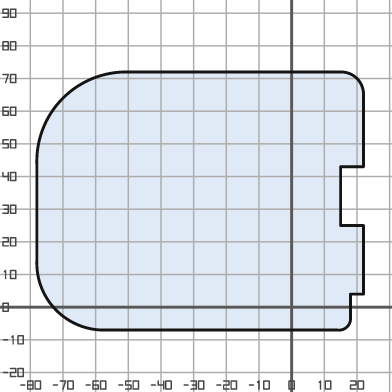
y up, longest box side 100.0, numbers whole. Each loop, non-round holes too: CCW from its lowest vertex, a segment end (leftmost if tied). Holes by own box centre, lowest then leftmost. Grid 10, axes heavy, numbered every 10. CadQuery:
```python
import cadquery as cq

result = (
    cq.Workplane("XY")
    .moveTo(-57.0, -7.0)
    .lineTo(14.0, -7.0)
    .threePointArc((17.0, -6.0), (18.0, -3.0))
    .lineTo(18.0, 4.0)
    .lineTo(22.0, 4.0)
    .lineTo(22.0, 25.0)
    .lineTo(15.0, 25.0)
    .lineTo(15.0, 43.0)
    .lineTo(22.0, 43.0)
    .lineTo(22.0, 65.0)
    .threePointArc((20.0, 70.0), (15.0, 72.0))
    .lineTo(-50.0, 72.0)
    .threePointArc((-70.0, 64.0), (-78.0, 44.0))
    .lineTo(-78.0, 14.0)
    .threePointArc((-72.0, -1.0), (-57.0, -7.0))
    .close()
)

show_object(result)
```